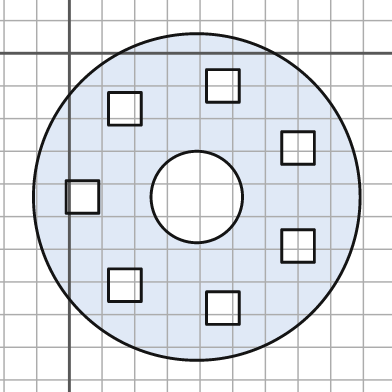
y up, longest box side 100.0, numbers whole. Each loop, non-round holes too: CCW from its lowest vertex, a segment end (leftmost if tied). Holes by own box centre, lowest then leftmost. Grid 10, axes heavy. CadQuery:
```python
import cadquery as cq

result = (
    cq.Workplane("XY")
    .moveTo(39.0, -44.0)
    .circle(50.0)
    .moveTo(42.0, -83.0)
    .lineTo(52.0, -83.0)
    .lineTo(52.0, -73.0)
    .lineTo(42.0, -73.0)
    .close()
    .moveTo(12.0, -76.0)
    .lineTo(22.0, -76.0)
    .lineTo(22.0, -66.0)
    .lineTo(12.0, -66.0)
    .close()
    .moveTo(65.0, -64.0)
    .lineTo(75.0, -64.0)
    .lineTo(75.0, -54.0)
    .lineTo(65.0, -54.0)
    .close()
    .moveTo(-1.0, -49.0)
    .lineTo(9.0, -49.0)
    .lineTo(9.0, -39.0)
    .lineTo(-1.0, -39.0)
    .close()
    .moveTo(39.0, -44.0)
    .circle(14.0)
    .moveTo(65.0, -34.0)
    .lineTo(75.0, -34.0)
    .lineTo(75.0, -24.0)
    .lineTo(65.0, -24.0)
    .close()
    .moveTo(12.0, -22.0)
    .lineTo(22.0, -22.0)
    .lineTo(22.0, -12.0)
    .lineTo(12.0, -12.0)
    .close()
    .moveTo(42.0, -15.0)
    .lineTo(52.0, -15.0)
    .lineTo(52.0, -5.0)
    .lineTo(42.0, -5.0)
    .close()
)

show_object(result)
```